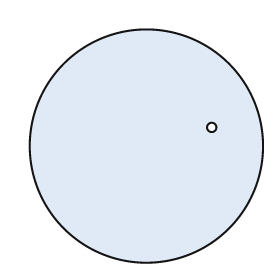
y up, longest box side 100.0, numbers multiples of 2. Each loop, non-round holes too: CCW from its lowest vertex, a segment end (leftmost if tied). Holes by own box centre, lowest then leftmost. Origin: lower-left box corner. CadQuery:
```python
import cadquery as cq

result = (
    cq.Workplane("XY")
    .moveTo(50.0, 50.0)
    .circle(50.0)
    .moveTo(78.0, 58.0)
    .circle(2.0)
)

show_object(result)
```